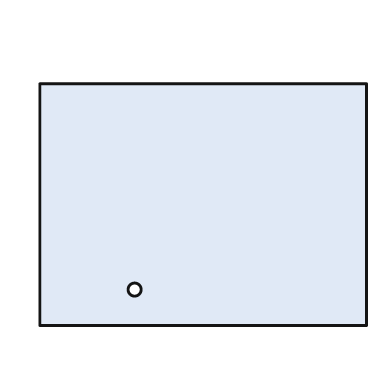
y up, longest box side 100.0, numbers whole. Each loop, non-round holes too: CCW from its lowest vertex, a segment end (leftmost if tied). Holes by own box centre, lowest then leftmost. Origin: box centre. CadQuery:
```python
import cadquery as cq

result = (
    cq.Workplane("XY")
    .moveTo(-50.0, -37.0)
    .lineTo(50.0, -37.0)
    .lineTo(50.0, 37.0)
    .lineTo(-50.0, 37.0)
    .close()
    .moveTo(-21.0, -26.0)
    .circle(2.0)
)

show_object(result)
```